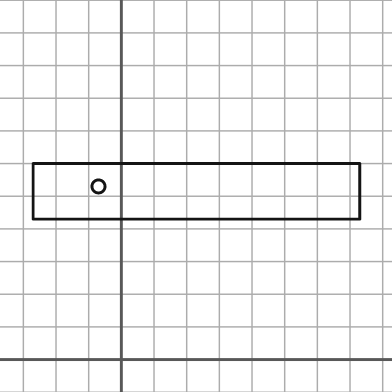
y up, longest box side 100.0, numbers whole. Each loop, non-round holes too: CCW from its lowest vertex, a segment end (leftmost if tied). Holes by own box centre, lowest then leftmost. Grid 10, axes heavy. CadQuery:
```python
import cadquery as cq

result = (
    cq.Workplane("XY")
    .moveTo(-27.0, 43.0)
    .lineTo(73.0, 43.0)
    .lineTo(73.0, 60.0)
    .lineTo(-27.0, 60.0)
    .close()
    .moveTo(-7.0, 53.0)
    .circle(2.0)
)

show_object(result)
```